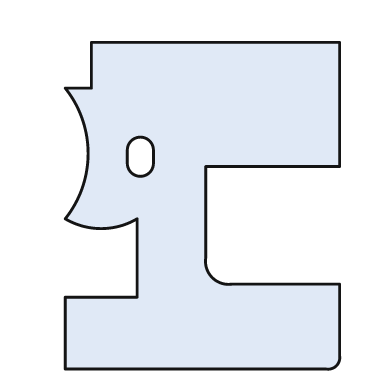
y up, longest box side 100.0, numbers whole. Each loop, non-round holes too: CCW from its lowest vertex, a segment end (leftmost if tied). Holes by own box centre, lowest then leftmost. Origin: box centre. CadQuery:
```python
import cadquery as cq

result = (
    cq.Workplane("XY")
    .moveTo(-42.0, -50.0)
    .lineTo(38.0, -50.0)
    .threePointArc((41.0, -49.0), (42.0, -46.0))
    .lineTo(42.0, -24.0)
    .lineTo(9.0, -24.0)
    .threePointArc((3.0, -22.0), (1.0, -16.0))
    .lineTo(1.0, 12.0)
    .lineTo(42.0, 12.0)
    .lineTo(42.0, 50.0)
    .lineTo(-34.0, 50.0)
    .lineTo(-34.0, 36.0)
    .lineTo(-42.0, 36.0)
    .threePointArc((-35.0, 16.0), (-42.0, -4.0))
    .threePointArc((-31.0, -7.0), (-20.0, -4.0))
    .lineTo(-20.0, -28.0)
    .lineTo(-42.0, -28.0)
    .close()
    .moveTo(-23.0, 13.0)
    .threePointArc((-19.0, 9.0), (-15.0, 13.0))
    .lineTo(-15.0, 17.0)
    .threePointArc((-19.0, 21.0), (-23.0, 17.0))
    .close()
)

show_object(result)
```